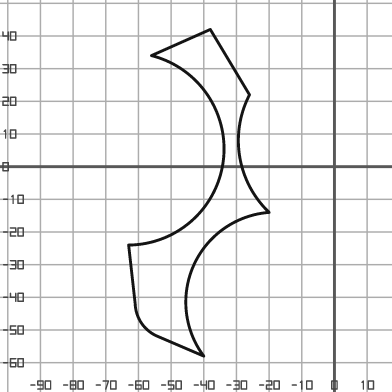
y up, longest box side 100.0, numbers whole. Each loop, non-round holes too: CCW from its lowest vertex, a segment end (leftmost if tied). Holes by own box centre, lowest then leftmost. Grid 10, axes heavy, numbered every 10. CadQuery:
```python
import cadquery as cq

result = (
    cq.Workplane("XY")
    .moveTo(-40.0, -58.0)
    .threePointArc((-43.0, -30.0), (-20.0, -14.0))
    .threePointArc((-29.0, 3.0), (-26.0, 22.0))
    .lineTo(-38.0, 42.0)
    .lineTo(-56.0, 34.0)
    .threePointArc((-34.0, 2.0), (-63.0, -24.0))
    .lineTo(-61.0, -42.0)
    .threePointArc((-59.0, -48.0), (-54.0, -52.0))
    .close()
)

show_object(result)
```